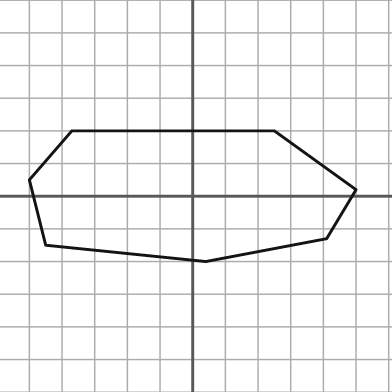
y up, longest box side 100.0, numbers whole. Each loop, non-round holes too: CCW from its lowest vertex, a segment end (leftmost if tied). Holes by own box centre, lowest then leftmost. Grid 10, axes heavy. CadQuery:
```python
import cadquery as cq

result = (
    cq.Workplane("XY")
    .moveTo(4.0, -20.0)
    .lineTo(41.0, -13.0)
    .lineTo(50.0, 2.0)
    .lineTo(25.0, 20.0)
    .lineTo(-37.0, 20.0)
    .lineTo(-50.0, 5.0)
    .lineTo(-45.0, -15.0)
    .close()
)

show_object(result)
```